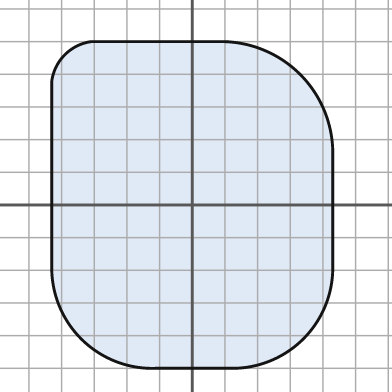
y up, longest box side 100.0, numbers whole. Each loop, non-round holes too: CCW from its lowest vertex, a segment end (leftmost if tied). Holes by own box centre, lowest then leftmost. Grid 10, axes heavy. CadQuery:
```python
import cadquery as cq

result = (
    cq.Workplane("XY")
    .moveTo(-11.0, -50.0)
    .lineTo(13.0, -50.0)
    .threePointArc((34.0, -41.0), (43.0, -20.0))
    .lineTo(43.0, 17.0)
    .threePointArc((33.0, 40.0), (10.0, 50.0))
    .lineTo(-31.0, 50.0)
    .threePointArc((-39.0, 46.0), (-43.0, 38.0))
    .lineTo(-43.0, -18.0)
    .threePointArc((-34.0, -41.0), (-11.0, -50.0))
    .close()
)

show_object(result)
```